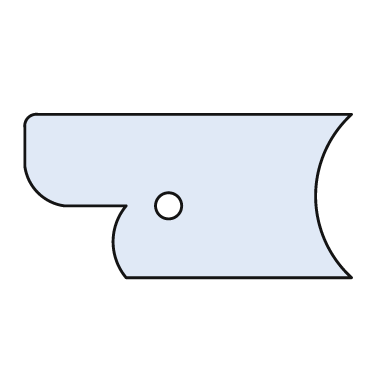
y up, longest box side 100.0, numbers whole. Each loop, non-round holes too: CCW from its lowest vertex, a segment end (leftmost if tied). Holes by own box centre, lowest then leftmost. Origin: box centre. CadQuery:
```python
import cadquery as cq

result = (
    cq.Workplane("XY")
    .moveTo(-19.0, -25.0)
    .lineTo(50.0, -25.0)
    .threePointArc((39.0, 0.0), (50.0, 25.0))
    .lineTo(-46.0, 25.0)
    .threePointArc((-49.0, 24.0), (-50.0, 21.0))
    .lineTo(-50.0, 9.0)
    .threePointArc((-46.0, 1.0), (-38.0, -3.0))
    .lineTo(-19.0, -3.0)
    .threePointArc((-23.0, -14.0), (-19.0, -25.0))
    .close()
    .moveTo(-6.0, -3.0)
    .circle(4.0)
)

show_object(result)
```